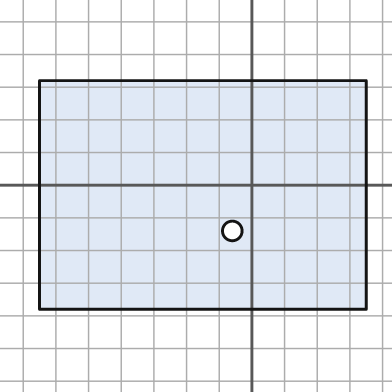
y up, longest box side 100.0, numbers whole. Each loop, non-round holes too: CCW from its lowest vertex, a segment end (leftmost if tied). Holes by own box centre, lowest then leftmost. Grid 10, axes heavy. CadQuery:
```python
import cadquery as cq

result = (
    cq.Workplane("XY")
    .moveTo(-65.0, -38.0)
    .lineTo(35.0, -38.0)
    .lineTo(35.0, 32.0)
    .lineTo(-65.0, 32.0)
    .close()
    .moveTo(-6.0, -14.0)
    .circle(3.0)
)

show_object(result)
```